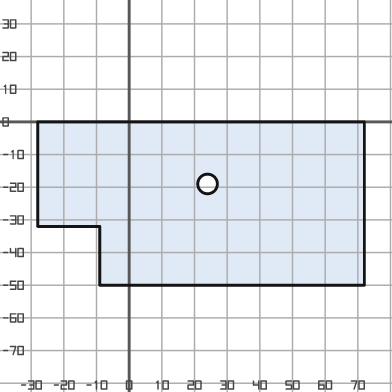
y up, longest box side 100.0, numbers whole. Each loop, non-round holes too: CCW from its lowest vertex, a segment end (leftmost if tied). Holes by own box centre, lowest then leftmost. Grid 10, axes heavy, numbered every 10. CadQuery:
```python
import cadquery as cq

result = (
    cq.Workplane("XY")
    .moveTo(-9.0, -50.0)
    .lineTo(72.0, -50.0)
    .lineTo(72.0, 0.0)
    .lineTo(-28.0, 0.0)
    .lineTo(-28.0, -32.0)
    .lineTo(-9.0, -32.0)
    .close()
    .moveTo(24.0, -19.0)
    .circle(3.0)
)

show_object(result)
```